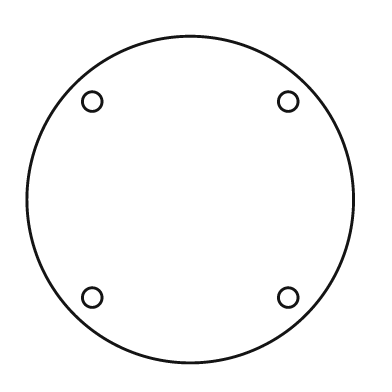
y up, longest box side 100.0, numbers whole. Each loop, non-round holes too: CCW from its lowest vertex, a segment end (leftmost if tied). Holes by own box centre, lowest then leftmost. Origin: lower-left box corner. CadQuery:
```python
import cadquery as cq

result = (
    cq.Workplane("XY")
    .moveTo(50.0, 50.0)
    .circle(50.0)
    .moveTo(20.0, 20.0)
    .circle(3.0)
    .moveTo(80.0, 20.0)
    .circle(3.0)
    .moveTo(20.0, 80.0)
    .circle(3.0)
    .moveTo(80.0, 80.0)
    .circle(3.0)
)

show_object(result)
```